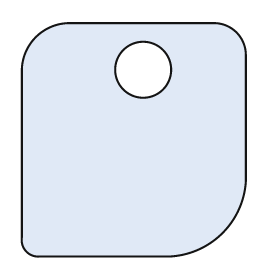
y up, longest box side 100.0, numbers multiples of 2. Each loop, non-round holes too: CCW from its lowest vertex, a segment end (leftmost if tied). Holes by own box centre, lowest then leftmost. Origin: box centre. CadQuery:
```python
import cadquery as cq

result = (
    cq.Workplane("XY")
    .moveTo(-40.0, -50.0)
    .lineTo(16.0, -50.0)
    .threePointArc((38.0, -40.0), (48.0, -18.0))
    .lineTo(48.0, 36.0)
    .threePointArc((44.0, 46.0), (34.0, 50.0))
    .lineTo(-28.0, 50.0)
    .threePointArc((-42.0, 44.0), (-48.0, 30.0))
    .lineTo(-48.0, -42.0)
    .threePointArc((-46.0, -48.0), (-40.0, -50.0))
    .close()
    .moveTo(4.0, 30.0)
    .circle(12.0)
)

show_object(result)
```